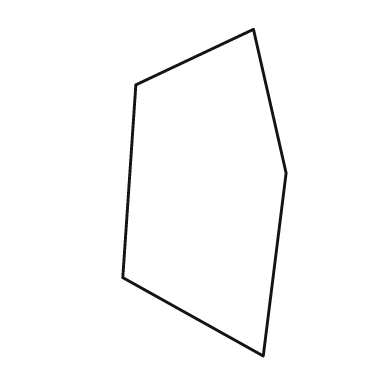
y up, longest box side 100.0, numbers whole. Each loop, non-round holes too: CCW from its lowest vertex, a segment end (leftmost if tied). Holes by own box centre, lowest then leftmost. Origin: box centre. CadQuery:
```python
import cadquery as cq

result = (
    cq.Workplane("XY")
    .moveTo(18.0, -50.0)
    .lineTo(25.0, 6.0)
    .lineTo(15.0, 50.0)
    .lineTo(-21.0, 33.0)
    .lineTo(-25.0, -26.0)
    .close()
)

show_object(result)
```